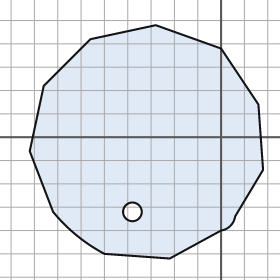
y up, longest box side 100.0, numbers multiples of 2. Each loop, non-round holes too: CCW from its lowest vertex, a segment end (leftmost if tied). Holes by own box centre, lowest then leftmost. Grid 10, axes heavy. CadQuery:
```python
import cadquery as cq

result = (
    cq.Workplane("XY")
    .moveTo(-22.0, -52.0)
    .lineTo(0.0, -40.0)
    .threePointArc((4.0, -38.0), (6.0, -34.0))
    .lineTo(18.0, -14.0)
    .lineTo(16.0, 14.0)
    .lineTo(0.0, 38.0)
    .lineTo(-28.0, 48.0)
    .lineTo(-56.0, 42.0)
    .lineTo(-76.0, 22.0)
    .lineTo(-82.0, -6.0)
    .lineTo(-72.0, -32.0)
    .threePointArc((-62.0, -42.0), (-50.0, -50.0))
    .close()
    .moveTo(-38.0, -32.0)
    .circle(4.0)
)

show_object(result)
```